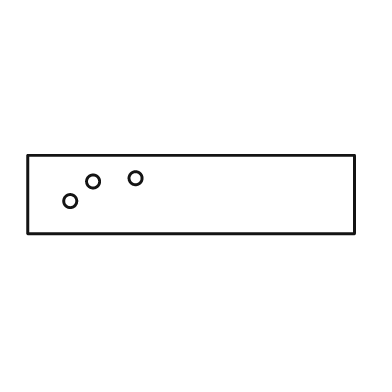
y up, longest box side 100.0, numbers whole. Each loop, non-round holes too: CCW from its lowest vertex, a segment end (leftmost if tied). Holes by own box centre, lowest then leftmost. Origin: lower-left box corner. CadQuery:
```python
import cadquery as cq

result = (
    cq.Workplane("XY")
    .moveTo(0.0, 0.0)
    .lineTo(100.0, 0.0)
    .lineTo(100.0, 24.0)
    .lineTo(0.0, 24.0)
    .close()
    .moveTo(13.0, 10.0)
    .circle(2.0)
    .moveTo(20.0, 16.0)
    .circle(2.0)
    .moveTo(33.0, 17.0)
    .circle(2.0)
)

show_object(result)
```